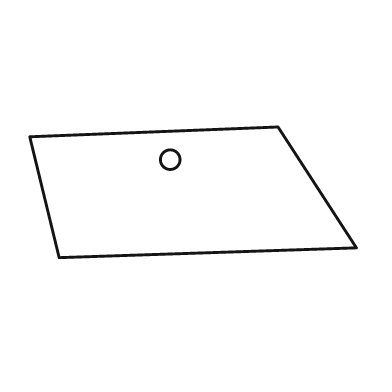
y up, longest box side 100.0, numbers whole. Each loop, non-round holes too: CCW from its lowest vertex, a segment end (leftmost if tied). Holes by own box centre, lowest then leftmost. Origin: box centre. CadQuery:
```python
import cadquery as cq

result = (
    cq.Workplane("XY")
    .moveTo(-41.0, -20.0)
    .lineTo(50.0, -17.0)
    .lineTo(26.0, 20.0)
    .lineTo(-50.0, 17.0)
    .close()
    .moveTo(-7.0, 10.0)
    .circle(3.0)
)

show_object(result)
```